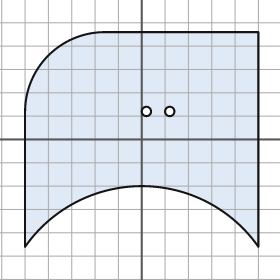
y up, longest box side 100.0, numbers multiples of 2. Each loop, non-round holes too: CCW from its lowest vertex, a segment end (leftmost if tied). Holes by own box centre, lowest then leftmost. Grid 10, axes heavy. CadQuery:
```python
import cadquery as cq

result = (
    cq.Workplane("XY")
    .moveTo(-50.0, -46.0)
    .threePointArc((0.0, -20.0), (50.0, -46.0))
    .lineTo(50.0, 46.0)
    .lineTo(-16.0, 46.0)
    .threePointArc((-40.0, 36.0), (-50.0, 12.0))
    .close()
    .moveTo(2.0, 12.0)
    .circle(2.0)
    .moveTo(12.0, 12.0)
    .circle(2.0)
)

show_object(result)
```